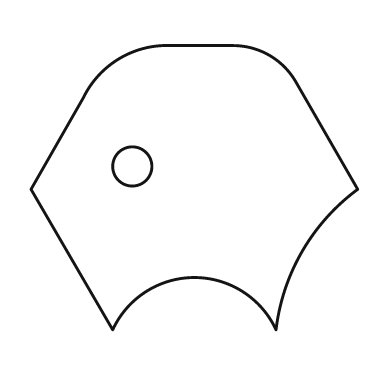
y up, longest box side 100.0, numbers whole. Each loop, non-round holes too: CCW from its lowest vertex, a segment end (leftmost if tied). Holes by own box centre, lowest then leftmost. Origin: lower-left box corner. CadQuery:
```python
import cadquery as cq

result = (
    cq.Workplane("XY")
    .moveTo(25.0, 0.0)
    .threePointArc((50.0, 16.0), (75.0, 0.0))
    .threePointArc((83.0, 24.0), (100.0, 43.0))
    .lineTo(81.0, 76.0)
    .threePointArc((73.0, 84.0), (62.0, 87.0))
    .lineTo(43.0, 87.0)
    .threePointArc((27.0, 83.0), (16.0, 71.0))
    .lineTo(0.0, 43.0)
    .close()
    .moveTo(31.0, 50.0)
    .circle(6.0)
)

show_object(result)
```